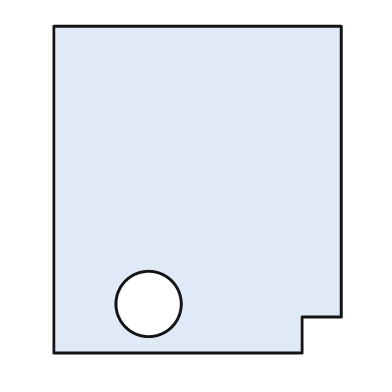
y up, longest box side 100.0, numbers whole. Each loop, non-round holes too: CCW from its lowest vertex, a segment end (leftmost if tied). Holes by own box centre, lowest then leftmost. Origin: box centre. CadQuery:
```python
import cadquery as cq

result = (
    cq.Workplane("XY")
    .moveTo(-44.0, -50.0)
    .lineTo(32.0, -50.0)
    .lineTo(32.0, -39.0)
    .lineTo(44.0, -39.0)
    .lineTo(44.0, 50.0)
    .lineTo(-44.0, 50.0)
    .close()
    .moveTo(-15.0, -35.0)
    .circle(10.0)
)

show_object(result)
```